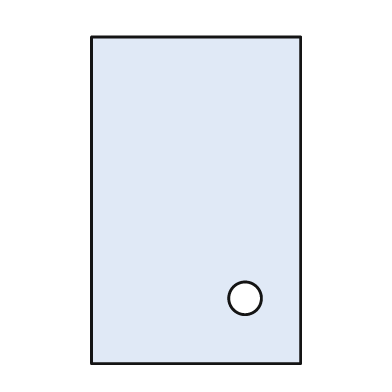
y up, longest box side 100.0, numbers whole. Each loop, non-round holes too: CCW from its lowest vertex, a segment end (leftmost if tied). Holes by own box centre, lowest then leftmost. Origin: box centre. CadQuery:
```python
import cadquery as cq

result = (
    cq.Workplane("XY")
    .moveTo(-32.0, -50.0)
    .lineTo(32.0, -50.0)
    .lineTo(32.0, 50.0)
    .lineTo(-32.0, 50.0)
    .close()
    .moveTo(15.0, -30.0)
    .circle(5.0)
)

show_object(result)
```